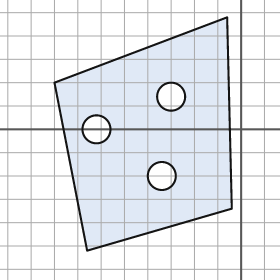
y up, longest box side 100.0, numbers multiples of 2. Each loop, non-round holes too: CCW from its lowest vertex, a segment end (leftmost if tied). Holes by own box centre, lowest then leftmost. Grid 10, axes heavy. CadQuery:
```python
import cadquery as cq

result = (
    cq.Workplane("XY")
    .moveTo(-66.0, -52.0)
    .lineTo(-4.0, -34.0)
    .lineTo(-6.0, 48.0)
    .lineTo(-80.0, 20.0)
    .close()
    .moveTo(-34.0, -20.0)
    .circle(6.0)
    .moveTo(-62.0, 0.0)
    .circle(6.0)
    .moveTo(-30.0, 14.0)
    .circle(6.0)
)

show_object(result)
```